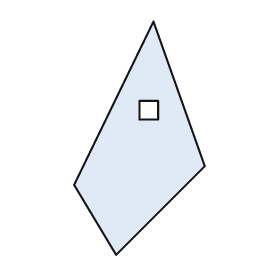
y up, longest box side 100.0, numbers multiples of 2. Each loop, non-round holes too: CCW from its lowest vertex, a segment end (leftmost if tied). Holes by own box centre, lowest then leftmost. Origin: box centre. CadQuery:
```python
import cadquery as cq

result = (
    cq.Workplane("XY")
    .moveTo(-10.0, -50.0)
    .lineTo(28.0, -12.0)
    .lineTo(6.0, 50.0)
    .lineTo(-28.0, -20.0)
    .close()
    .moveTo(0.0, 8.0)
    .lineTo(8.0, 8.0)
    .lineTo(8.0, 16.0)
    .lineTo(0.0, 16.0)
    .close()
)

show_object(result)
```